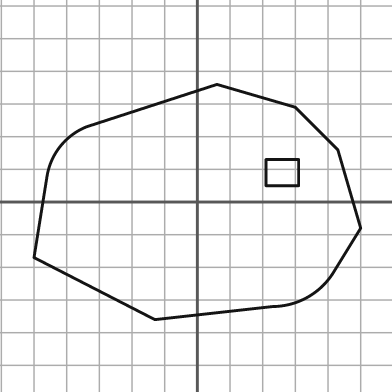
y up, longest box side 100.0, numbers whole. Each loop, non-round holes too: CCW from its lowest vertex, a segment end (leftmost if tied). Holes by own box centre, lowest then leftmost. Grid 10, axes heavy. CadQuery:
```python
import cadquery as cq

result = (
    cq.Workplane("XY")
    .moveTo(-13.0, -36.0)
    .lineTo(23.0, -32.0)
    .threePointArc((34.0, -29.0), (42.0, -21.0))
    .lineTo(50.0, -8.0)
    .lineTo(43.0, 16.0)
    .lineTo(30.0, 29.0)
    .lineTo(6.0, 36.0)
    .lineTo(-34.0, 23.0)
    .threePointArc((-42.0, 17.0), (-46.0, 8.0))
    .lineTo(-50.0, -17.0)
    .close()
    .moveTo(21.0, 5.0)
    .lineTo(31.0, 5.0)
    .lineTo(31.0, 13.0)
    .lineTo(21.0, 13.0)
    .close()
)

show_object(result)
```